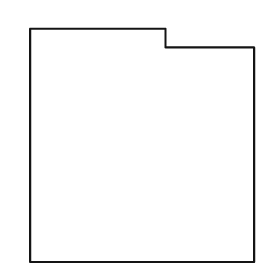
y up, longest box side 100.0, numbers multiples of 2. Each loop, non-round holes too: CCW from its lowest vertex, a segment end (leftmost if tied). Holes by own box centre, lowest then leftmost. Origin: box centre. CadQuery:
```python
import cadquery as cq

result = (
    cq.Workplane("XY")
    .moveTo(-48.0, -50.0)
    .lineTo(48.0, -50.0)
    .lineTo(48.0, 42.0)
    .lineTo(10.0, 42.0)
    .lineTo(10.0, 50.0)
    .lineTo(-48.0, 50.0)
    .close()
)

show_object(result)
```